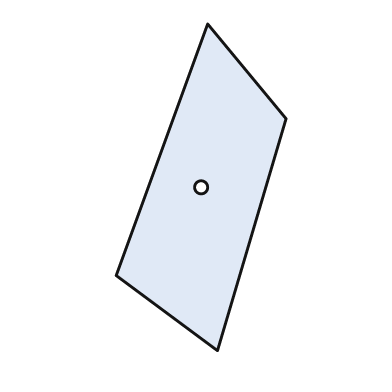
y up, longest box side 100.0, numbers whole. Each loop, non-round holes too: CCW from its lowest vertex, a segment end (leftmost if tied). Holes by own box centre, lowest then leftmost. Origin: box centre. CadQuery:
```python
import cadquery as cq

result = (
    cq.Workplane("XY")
    .moveTo(5.0, -50.0)
    .lineTo(26.0, 21.0)
    .lineTo(2.0, 50.0)
    .lineTo(-26.0, -27.0)
    .close()
    .moveTo(0.0, 0.0)
    .circle(2.0)
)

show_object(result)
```